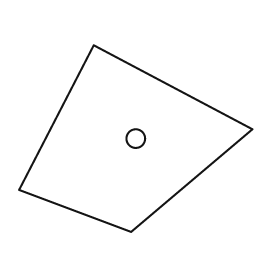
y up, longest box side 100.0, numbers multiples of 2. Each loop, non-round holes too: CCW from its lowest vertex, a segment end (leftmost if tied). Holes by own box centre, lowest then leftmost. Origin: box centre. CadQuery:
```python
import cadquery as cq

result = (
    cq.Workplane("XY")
    .moveTo(-2.0, -40.0)
    .lineTo(50.0, 4.0)
    .lineTo(-18.0, 40.0)
    .lineTo(-50.0, -22.0)
    .close()
    .moveTo(0.0, 0.0)
    .circle(4.0)
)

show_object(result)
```